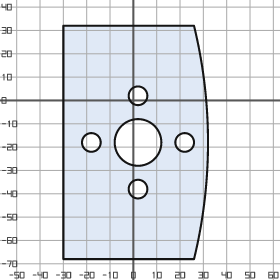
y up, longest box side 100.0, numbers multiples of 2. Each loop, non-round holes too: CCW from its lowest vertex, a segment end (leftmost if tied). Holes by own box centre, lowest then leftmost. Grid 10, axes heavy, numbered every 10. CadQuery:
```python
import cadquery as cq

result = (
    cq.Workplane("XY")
    .moveTo(-30.0, -68.0)
    .lineTo(26.0, -68.0)
    .threePointArc((32.0, -18.0), (26.0, 32.0))
    .lineTo(-30.0, 32.0)
    .close()
    .moveTo(2.0, -38.0)
    .circle(4.0)
    .moveTo(-18.0, -18.0)
    .circle(4.0)
    .moveTo(2.0, -18.0)
    .circle(10.0)
    .moveTo(22.0, -18.0)
    .circle(4.0)
    .moveTo(2.0, 2.0)
    .circle(4.0)
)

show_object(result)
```